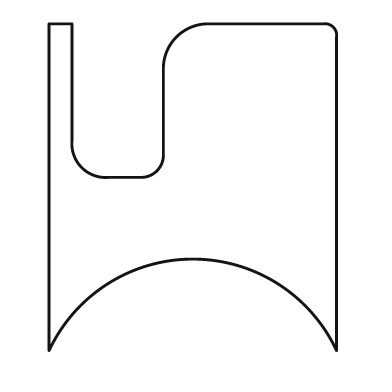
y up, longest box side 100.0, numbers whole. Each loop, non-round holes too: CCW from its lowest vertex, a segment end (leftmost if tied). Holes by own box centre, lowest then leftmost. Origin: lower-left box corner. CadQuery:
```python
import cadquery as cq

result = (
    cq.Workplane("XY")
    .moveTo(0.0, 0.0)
    .threePointArc((44.0, 28.0), (88.0, 0.0))
    .lineTo(88.0, 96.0)
    .threePointArc((87.0, 99.0), (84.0, 100.0))
    .lineTo(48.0, 100.0)
    .threePointArc((39.0, 96.0), (35.0, 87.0))
    .lineTo(35.0, 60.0)
    .threePointArc((33.0, 55.0), (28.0, 53.0))
    .lineTo(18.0, 53.0)
    .threePointArc((10.0, 56.0), (7.0, 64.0))
    .lineTo(7.0, 100.0)
    .lineTo(0.0, 100.0)
    .close()
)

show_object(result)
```